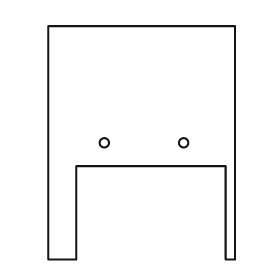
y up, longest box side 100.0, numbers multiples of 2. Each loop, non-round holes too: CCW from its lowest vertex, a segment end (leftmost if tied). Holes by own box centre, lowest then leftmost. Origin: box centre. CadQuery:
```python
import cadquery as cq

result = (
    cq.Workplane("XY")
    .moveTo(-40.0, -50.0)
    .lineTo(-28.0, -50.0)
    .lineTo(-28.0, -10.0)
    .lineTo(36.0, -10.0)
    .lineTo(36.0, -50.0)
    .lineTo(40.0, -50.0)
    .lineTo(40.0, 50.0)
    .lineTo(-40.0, 50.0)
    .close()
    .moveTo(-16.0, 0.0)
    .circle(2.0)
    .moveTo(18.0, 0.0)
    .circle(2.0)
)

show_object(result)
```